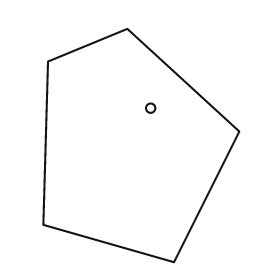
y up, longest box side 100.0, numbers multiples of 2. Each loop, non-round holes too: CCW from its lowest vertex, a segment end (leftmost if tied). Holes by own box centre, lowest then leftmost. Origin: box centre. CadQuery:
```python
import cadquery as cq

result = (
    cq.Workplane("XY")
    .moveTo(14.0, -50.0)
    .lineTo(42.0, 6.0)
    .lineTo(-6.0, 50.0)
    .lineTo(-40.0, 36.0)
    .lineTo(-42.0, -34.0)
    .close()
    .moveTo(4.0, 16.0)
    .circle(2.0)
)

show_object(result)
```